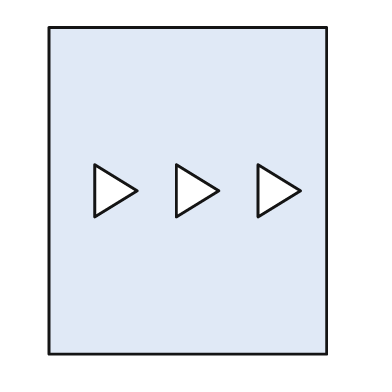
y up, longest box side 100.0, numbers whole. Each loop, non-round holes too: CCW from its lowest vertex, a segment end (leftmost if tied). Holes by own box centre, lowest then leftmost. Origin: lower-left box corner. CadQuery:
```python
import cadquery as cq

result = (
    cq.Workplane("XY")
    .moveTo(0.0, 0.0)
    .lineTo(85.0, 0.0)
    .lineTo(85.0, 100.0)
    .lineTo(0.0, 100.0)
    .close()
    .moveTo(14.0, 42.0)
    .lineTo(27.0, 50.0)
    .lineTo(14.0, 58.0)
    .close()
    .moveTo(39.0, 42.0)
    .lineTo(52.0, 50.0)
    .lineTo(39.0, 58.0)
    .close()
    .moveTo(64.0, 42.0)
    .lineTo(77.0, 50.0)
    .lineTo(64.0, 58.0)
    .close()
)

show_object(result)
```